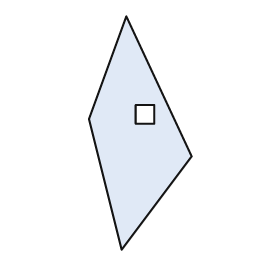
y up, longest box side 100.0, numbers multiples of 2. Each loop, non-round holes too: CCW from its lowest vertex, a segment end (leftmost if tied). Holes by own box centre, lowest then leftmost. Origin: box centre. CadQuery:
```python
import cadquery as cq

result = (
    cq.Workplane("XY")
    .moveTo(-8.0, -50.0)
    .lineTo(22.0, -10.0)
    .lineTo(-6.0, 50.0)
    .lineTo(-22.0, 6.0)
    .close()
    .moveTo(-2.0, 4.0)
    .lineTo(6.0, 4.0)
    .lineTo(6.0, 12.0)
    .lineTo(-2.0, 12.0)
    .close()
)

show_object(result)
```